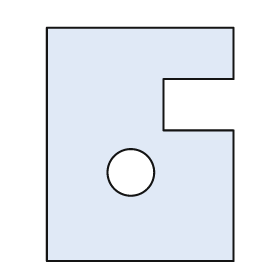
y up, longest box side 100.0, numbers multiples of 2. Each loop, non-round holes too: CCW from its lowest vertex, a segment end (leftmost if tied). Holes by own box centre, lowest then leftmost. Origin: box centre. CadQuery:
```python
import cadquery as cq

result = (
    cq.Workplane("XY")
    .moveTo(-40.0, -50.0)
    .lineTo(40.0, -50.0)
    .lineTo(40.0, 6.0)
    .lineTo(10.0, 6.0)
    .lineTo(10.0, 28.0)
    .lineTo(40.0, 28.0)
    .lineTo(40.0, 50.0)
    .lineTo(-40.0, 50.0)
    .close()
    .moveTo(-4.0, -12.0)
    .circle(10.0)
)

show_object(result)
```